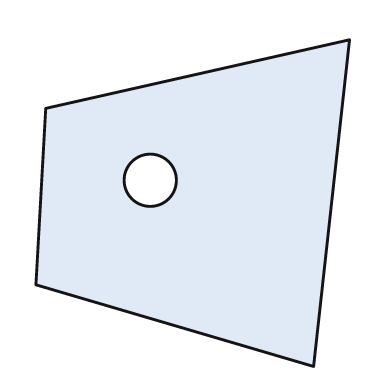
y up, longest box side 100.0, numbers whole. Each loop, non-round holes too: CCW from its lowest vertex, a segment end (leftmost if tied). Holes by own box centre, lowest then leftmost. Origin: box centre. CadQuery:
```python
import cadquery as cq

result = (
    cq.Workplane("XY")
    .moveTo(37.0, -50.0)
    .lineTo(48.0, 50.0)
    .lineTo(-45.0, 29.0)
    .lineTo(-48.0, -25.0)
    .close()
    .moveTo(-13.0, 7.0)
    .circle(8.0)
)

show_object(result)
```